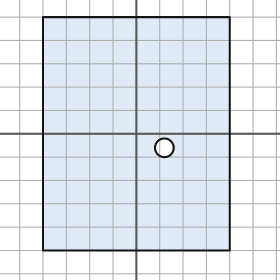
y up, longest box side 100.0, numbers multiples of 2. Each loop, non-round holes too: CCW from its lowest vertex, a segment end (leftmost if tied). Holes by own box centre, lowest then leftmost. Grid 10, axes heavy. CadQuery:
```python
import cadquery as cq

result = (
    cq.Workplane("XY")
    .moveTo(-40.0, -50.0)
    .lineTo(40.0, -50.0)
    .lineTo(40.0, 50.0)
    .lineTo(-40.0, 50.0)
    .close()
    .moveTo(12.0, -6.0)
    .circle(4.0)
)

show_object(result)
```